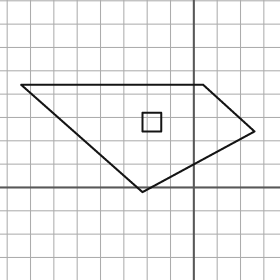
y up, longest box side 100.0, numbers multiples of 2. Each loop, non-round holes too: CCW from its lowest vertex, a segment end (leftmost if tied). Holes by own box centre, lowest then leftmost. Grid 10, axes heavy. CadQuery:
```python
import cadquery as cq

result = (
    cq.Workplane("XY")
    .moveTo(-22.0, -2.0)
    .lineTo(26.0, 24.0)
    .lineTo(4.0, 44.0)
    .lineTo(-74.0, 44.0)
    .close()
    .moveTo(-22.0, 24.0)
    .lineTo(-14.0, 24.0)
    .lineTo(-14.0, 32.0)
    .lineTo(-22.0, 32.0)
    .close()
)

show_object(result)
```